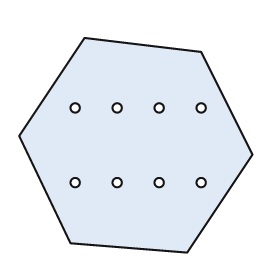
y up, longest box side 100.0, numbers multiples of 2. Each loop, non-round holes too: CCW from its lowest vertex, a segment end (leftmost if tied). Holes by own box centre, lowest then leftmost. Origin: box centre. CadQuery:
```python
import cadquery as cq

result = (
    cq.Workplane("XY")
    .moveTo(22.0, -46.0)
    .lineTo(50.0, -4.0)
    .lineTo(28.0, 40.0)
    .lineTo(-22.0, 46.0)
    .lineTo(-50.0, 4.0)
    .lineTo(-28.0, -42.0)
    .close()
    .moveTo(-26.0, -16.0)
    .circle(2.0)
    .moveTo(-8.0, -16.0)
    .circle(2.0)
    .moveTo(10.0, -16.0)
    .circle(2.0)
    .moveTo(28.0, -16.0)
    .circle(2.0)
    .moveTo(-26.0, 16.0)
    .circle(2.0)
    .moveTo(-8.0, 16.0)
    .circle(2.0)
    .moveTo(10.0, 16.0)
    .circle(2.0)
    .moveTo(28.0, 16.0)
    .circle(2.0)
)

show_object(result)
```